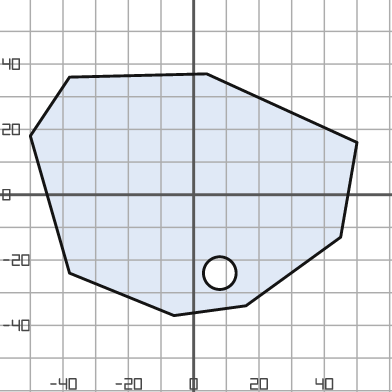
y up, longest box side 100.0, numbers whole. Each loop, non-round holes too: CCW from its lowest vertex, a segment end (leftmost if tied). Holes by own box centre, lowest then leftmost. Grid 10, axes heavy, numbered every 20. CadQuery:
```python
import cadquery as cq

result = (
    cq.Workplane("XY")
    .moveTo(-6.0, -37.0)
    .lineTo(16.0, -34.0)
    .lineTo(45.0, -13.0)
    .lineTo(50.0, 16.0)
    .lineTo(4.0, 37.0)
    .lineTo(-38.0, 36.0)
    .lineTo(-50.0, 18.0)
    .lineTo(-38.0, -24.0)
    .close()
    .moveTo(8.0, -24.0)
    .circle(5.0)
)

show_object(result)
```